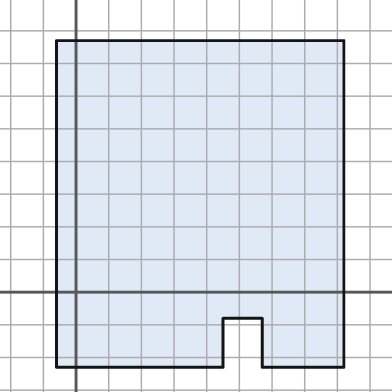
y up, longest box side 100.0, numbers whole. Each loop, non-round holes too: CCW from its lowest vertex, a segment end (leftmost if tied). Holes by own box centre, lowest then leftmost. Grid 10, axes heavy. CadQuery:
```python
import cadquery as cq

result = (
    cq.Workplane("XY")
    .moveTo(-6.0, -23.0)
    .lineTo(45.0, -23.0)
    .lineTo(45.0, -8.0)
    .lineTo(57.0, -8.0)
    .lineTo(57.0, -23.0)
    .lineTo(82.0, -23.0)
    .lineTo(82.0, 77.0)
    .lineTo(-6.0, 77.0)
    .close()
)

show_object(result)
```